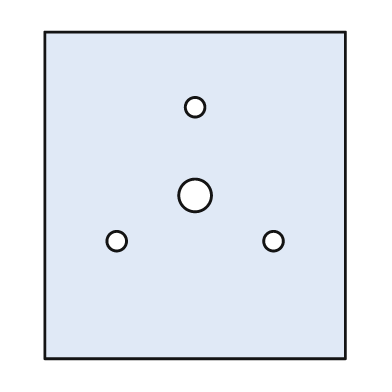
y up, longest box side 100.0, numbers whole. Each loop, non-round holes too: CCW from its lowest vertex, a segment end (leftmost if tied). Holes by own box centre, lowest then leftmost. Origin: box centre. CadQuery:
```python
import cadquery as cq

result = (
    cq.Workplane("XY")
    .moveTo(-46.0, -50.0)
    .lineTo(46.0, -50.0)
    .lineTo(46.0, 50.0)
    .lineTo(-46.0, 50.0)
    .close()
    .moveTo(-24.0, -14.0)
    .circle(3.0)
    .moveTo(24.0, -14.0)
    .circle(3.0)
    .moveTo(0.0, 0.0)
    .circle(5.0)
    .moveTo(0.0, 27.0)
    .circle(3.0)
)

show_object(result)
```